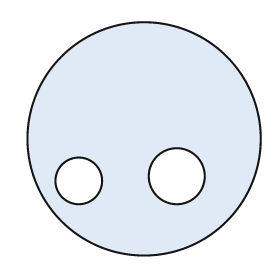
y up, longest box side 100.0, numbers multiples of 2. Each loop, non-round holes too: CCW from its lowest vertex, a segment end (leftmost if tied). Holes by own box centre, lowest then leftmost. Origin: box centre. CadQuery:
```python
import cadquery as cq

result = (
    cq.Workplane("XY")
    .moveTo(0.0, 0.0)
    .circle(50.0)
    .moveTo(-28.0, -18.0)
    .circle(10.0)
    .moveTo(14.0, -16.0)
    .circle(12.0)
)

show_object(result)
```